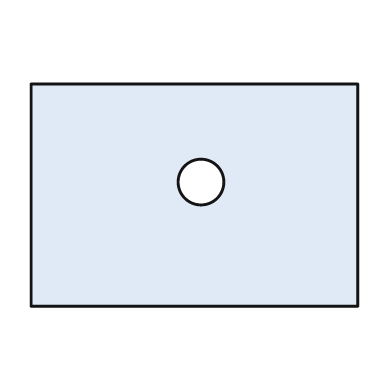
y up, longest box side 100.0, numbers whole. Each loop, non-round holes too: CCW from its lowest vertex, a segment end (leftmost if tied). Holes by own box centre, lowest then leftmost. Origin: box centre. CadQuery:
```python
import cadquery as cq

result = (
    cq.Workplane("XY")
    .moveTo(-50.0, -34.0)
    .lineTo(50.0, -34.0)
    .lineTo(50.0, 34.0)
    .lineTo(-50.0, 34.0)
    .close()
    .moveTo(2.0, 4.0)
    .circle(7.0)
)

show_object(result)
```